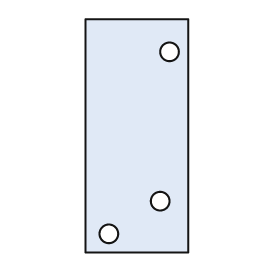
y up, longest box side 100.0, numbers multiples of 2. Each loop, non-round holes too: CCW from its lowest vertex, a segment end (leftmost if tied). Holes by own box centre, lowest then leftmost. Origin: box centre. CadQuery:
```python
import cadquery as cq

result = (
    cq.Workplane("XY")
    .moveTo(-22.0, -50.0)
    .lineTo(22.0, -50.0)
    .lineTo(22.0, 50.0)
    .lineTo(-22.0, 50.0)
    .close()
    .moveTo(-12.0, -42.0)
    .circle(4.0)
    .moveTo(10.0, -28.0)
    .circle(4.0)
    .moveTo(14.0, 36.0)
    .circle(4.0)
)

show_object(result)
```